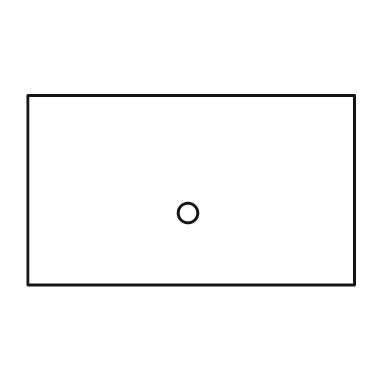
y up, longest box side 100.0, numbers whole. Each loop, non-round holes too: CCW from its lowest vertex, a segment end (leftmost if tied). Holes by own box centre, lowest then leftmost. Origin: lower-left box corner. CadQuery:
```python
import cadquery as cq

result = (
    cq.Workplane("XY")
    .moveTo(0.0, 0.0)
    .lineTo(100.0, 0.0)
    .lineTo(100.0, 58.0)
    .lineTo(0.0, 58.0)
    .close()
    .moveTo(49.0, 22.0)
    .circle(3.0)
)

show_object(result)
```